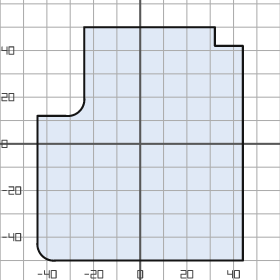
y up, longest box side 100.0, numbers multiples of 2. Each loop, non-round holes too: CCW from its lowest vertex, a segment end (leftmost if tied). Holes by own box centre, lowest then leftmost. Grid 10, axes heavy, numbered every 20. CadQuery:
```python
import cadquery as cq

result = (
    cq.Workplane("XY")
    .moveTo(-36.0, -50.0)
    .lineTo(44.0, -50.0)
    .lineTo(44.0, 42.0)
    .lineTo(32.0, 42.0)
    .lineTo(32.0, 50.0)
    .lineTo(-24.0, 50.0)
    .lineTo(-24.0, 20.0)
    .threePointArc((-26.0, 14.0), (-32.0, 12.0))
    .lineTo(-44.0, 12.0)
    .lineTo(-44.0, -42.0)
    .threePointArc((-42.0, -48.0), (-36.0, -50.0))
    .close()
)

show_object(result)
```